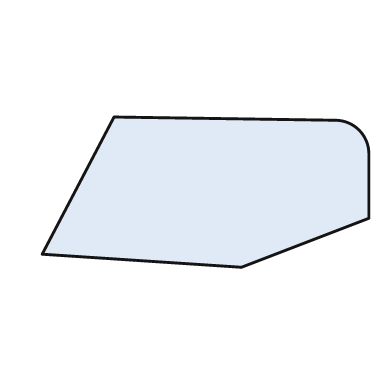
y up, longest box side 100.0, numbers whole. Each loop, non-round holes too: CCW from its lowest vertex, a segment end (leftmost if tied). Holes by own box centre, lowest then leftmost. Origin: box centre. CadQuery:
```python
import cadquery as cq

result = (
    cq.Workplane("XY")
    .moveTo(11.0, -23.0)
    .lineTo(50.0, -8.0)
    .lineTo(50.0, 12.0)
    .threePointArc((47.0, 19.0), (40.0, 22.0))
    .lineTo(-28.0, 23.0)
    .lineTo(-50.0, -19.0)
    .close()
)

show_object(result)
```